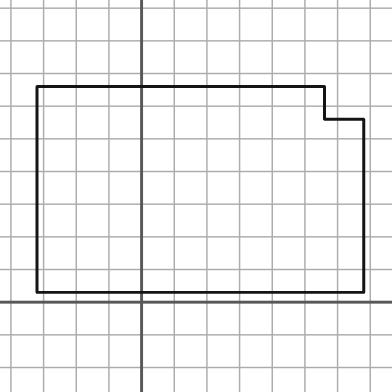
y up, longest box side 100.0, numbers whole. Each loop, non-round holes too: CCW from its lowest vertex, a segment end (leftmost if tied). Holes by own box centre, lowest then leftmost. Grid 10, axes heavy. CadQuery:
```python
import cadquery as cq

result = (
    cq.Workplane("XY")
    .moveTo(-32.0, 3.0)
    .lineTo(68.0, 3.0)
    .lineTo(68.0, 56.0)
    .lineTo(56.0, 56.0)
    .lineTo(56.0, 66.0)
    .lineTo(-32.0, 66.0)
    .close()
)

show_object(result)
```